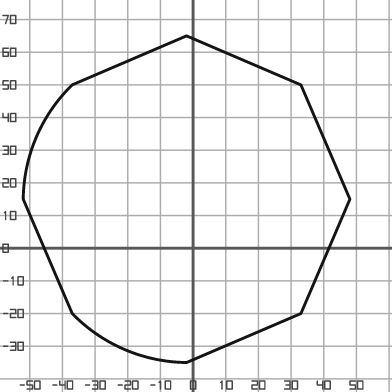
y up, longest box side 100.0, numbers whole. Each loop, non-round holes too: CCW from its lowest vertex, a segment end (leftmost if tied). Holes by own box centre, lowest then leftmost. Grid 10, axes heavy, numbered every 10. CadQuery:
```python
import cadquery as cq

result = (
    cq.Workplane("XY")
    .moveTo(-2.0, -35.0)
    .lineTo(33.0, -20.0)
    .lineTo(48.0, 15.0)
    .lineTo(33.0, 50.0)
    .lineTo(-2.0, 65.0)
    .lineTo(-37.0, 50.0)
    .threePointArc((-48.0, 34.0), (-52.0, 15.0))
    .lineTo(-37.0, -20.0)
    .threePointArc((-21.0, -31.0), (-2.0, -35.0))
    .close()
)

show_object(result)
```